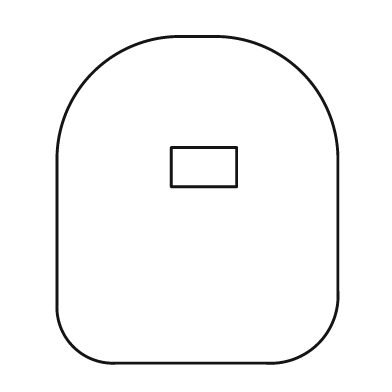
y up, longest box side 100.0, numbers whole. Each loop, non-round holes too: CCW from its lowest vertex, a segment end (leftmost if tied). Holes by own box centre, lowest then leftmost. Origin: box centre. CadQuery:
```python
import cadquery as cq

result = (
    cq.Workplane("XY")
    .moveTo(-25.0, -50.0)
    .lineTo(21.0, -50.0)
    .threePointArc((37.0, -44.0), (43.0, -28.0))
    .lineTo(43.0, 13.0)
    .threePointArc((32.0, 39.0), (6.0, 50.0))
    .lineTo(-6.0, 50.0)
    .threePointArc((-32.0, 39.0), (-43.0, 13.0))
    .lineTo(-43.0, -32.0)
    .threePointArc((-38.0, -45.0), (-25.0, -50.0))
    .close()
    .moveTo(-8.0, 4.0)
    .lineTo(12.0, 4.0)
    .lineTo(12.0, 16.0)
    .lineTo(-8.0, 16.0)
    .close()
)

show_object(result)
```